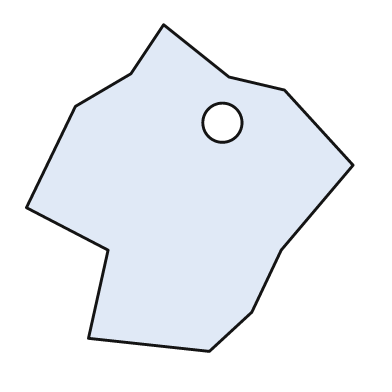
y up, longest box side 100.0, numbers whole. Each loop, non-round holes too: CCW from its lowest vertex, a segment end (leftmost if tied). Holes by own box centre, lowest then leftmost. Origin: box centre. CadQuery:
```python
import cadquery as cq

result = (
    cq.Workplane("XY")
    .moveTo(6.0, -50.0)
    .lineTo(19.0, -38.0)
    .lineTo(28.0, -19.0)
    .lineTo(50.0, 7.0)
    .lineTo(29.0, 30.0)
    .lineTo(12.0, 34.0)
    .lineTo(-8.0, 50.0)
    .lineTo(-18.0, 35.0)
    .lineTo(-35.0, 25.0)
    .lineTo(-50.0, -6.0)
    .lineTo(-25.0, -19.0)
    .lineTo(-31.0, -46.0)
    .close()
    .moveTo(10.0, 20.0)
    .circle(6.0)
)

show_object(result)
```